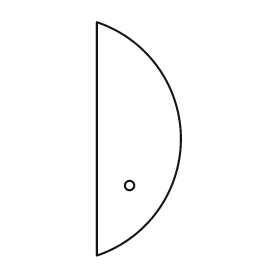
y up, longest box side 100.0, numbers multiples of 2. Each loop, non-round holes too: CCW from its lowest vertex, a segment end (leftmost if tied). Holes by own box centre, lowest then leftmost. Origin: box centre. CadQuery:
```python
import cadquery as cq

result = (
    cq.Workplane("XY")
    .moveTo(-18.0, -50.0)
    .threePointArc((18.0, 0.0), (-18.0, 50.0))
    .close()
    .moveTo(-4.0, -20.0)
    .circle(2.0)
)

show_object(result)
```